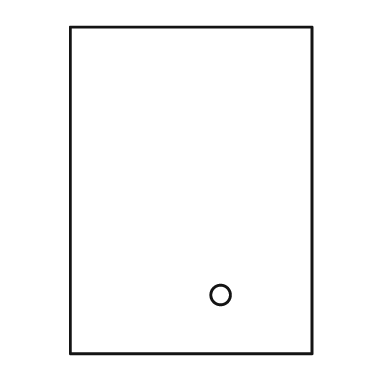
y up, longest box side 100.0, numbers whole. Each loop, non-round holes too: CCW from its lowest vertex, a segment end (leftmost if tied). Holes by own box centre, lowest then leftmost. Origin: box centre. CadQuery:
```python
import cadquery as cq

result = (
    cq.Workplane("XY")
    .moveTo(-37.0, -50.0)
    .lineTo(37.0, -50.0)
    .lineTo(37.0, 50.0)
    .lineTo(-37.0, 50.0)
    .close()
    .moveTo(9.0, -32.0)
    .circle(3.0)
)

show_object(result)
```